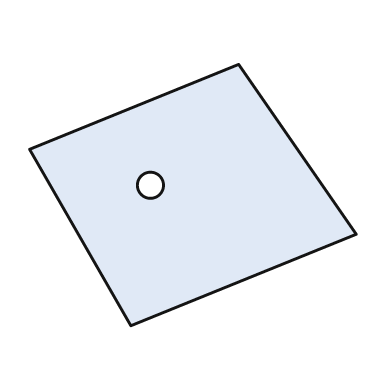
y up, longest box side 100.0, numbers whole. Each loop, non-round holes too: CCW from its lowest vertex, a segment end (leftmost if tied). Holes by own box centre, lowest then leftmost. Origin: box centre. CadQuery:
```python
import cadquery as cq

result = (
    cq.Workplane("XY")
    .moveTo(-19.0, -40.0)
    .lineTo(50.0, -12.0)
    .lineTo(14.0, 40.0)
    .lineTo(-50.0, 14.0)
    .close()
    .moveTo(-13.0, 3.0)
    .circle(4.0)
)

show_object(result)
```